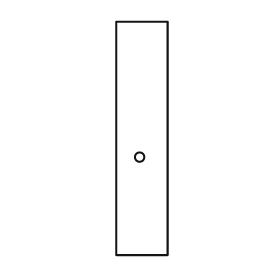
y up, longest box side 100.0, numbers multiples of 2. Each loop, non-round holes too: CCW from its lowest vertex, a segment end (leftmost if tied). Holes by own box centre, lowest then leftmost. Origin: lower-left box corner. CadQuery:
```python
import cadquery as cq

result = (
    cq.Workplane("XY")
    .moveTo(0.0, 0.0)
    .lineTo(22.0, 0.0)
    .lineTo(22.0, 100.0)
    .lineTo(0.0, 100.0)
    .close()
    .moveTo(10.0, 42.0)
    .circle(2.0)
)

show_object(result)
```